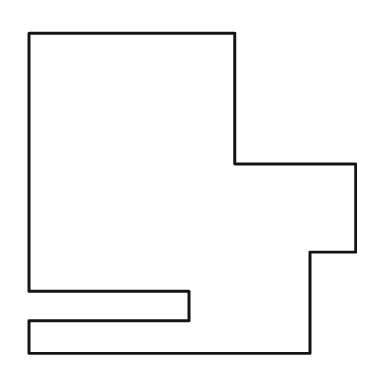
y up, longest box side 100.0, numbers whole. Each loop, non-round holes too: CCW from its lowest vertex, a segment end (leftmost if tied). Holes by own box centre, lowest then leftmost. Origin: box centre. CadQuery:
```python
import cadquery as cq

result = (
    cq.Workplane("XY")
    .moveTo(-50.0, -49.0)
    .lineTo(36.0, -49.0)
    .lineTo(36.0, -18.0)
    .lineTo(50.0, -18.0)
    .lineTo(50.0, 9.0)
    .lineTo(13.0, 9.0)
    .lineTo(13.0, 49.0)
    .lineTo(-50.0, 49.0)
    .lineTo(-50.0, -30.0)
    .lineTo(-1.0, -30.0)
    .lineTo(-1.0, -39.0)
    .lineTo(-50.0, -39.0)
    .close()
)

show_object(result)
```